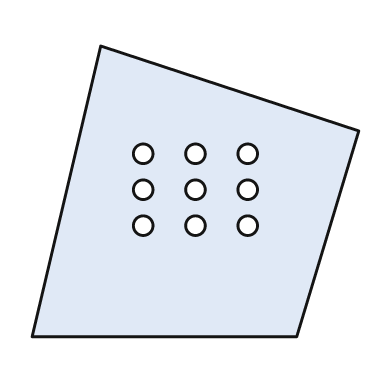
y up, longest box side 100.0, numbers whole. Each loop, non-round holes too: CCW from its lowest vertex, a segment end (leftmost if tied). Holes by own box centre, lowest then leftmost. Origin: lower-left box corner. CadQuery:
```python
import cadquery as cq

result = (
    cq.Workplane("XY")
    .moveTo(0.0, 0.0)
    .lineTo(81.0, 0.0)
    .lineTo(100.0, 63.0)
    .lineTo(21.0, 89.0)
    .close()
    .moveTo(34.0, 34.0)
    .circle(3.0)
    .moveTo(50.0, 34.0)
    .circle(3.0)
    .moveTo(66.0, 34.0)
    .circle(3.0)
    .moveTo(34.0, 45.0)
    .circle(3.0)
    .moveTo(50.0, 45.0)
    .circle(3.0)
    .moveTo(66.0, 45.0)
    .circle(3.0)
    .moveTo(34.0, 56.0)
    .circle(3.0)
    .moveTo(50.0, 56.0)
    .circle(3.0)
    .moveTo(66.0, 56.0)
    .circle(3.0)
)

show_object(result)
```